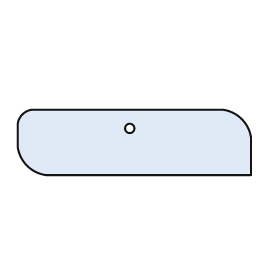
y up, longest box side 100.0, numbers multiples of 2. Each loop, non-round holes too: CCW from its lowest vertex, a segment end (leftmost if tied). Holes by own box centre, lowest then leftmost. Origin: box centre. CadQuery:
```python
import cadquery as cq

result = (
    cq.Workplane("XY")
    .moveTo(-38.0, -14.0)
    .lineTo(50.0, -14.0)
    .lineTo(50.0, 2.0)
    .threePointArc((46.0, 10.0), (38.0, 14.0))
    .lineTo(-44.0, 14.0)
    .threePointArc((-48.0, 12.0), (-50.0, 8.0))
    .lineTo(-50.0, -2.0)
    .threePointArc((-46.0, -10.0), (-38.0, -14.0))
    .close()
    .moveTo(-2.0, 6.0)
    .circle(2.0)
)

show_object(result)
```